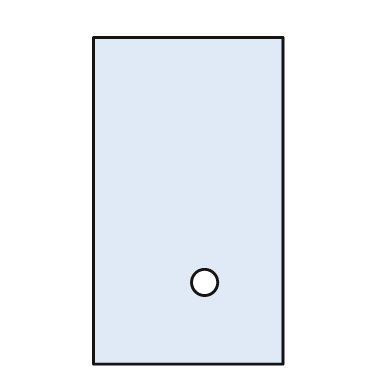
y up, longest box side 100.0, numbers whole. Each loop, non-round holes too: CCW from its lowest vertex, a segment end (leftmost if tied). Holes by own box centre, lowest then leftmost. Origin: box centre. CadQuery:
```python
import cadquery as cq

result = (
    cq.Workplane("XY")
    .moveTo(-29.0, -50.0)
    .lineTo(29.0, -50.0)
    .lineTo(29.0, 50.0)
    .lineTo(-29.0, 50.0)
    .close()
    .moveTo(5.0, -25.0)
    .circle(4.0)
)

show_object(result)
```